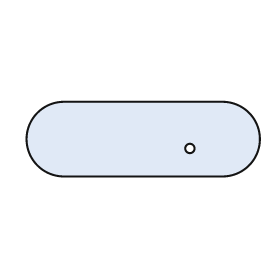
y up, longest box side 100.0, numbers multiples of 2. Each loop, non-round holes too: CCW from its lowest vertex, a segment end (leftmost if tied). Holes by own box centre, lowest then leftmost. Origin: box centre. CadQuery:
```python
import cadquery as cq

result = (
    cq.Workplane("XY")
    .moveTo(-34.0, -16.0)
    .lineTo(34.0, -16.0)
    .threePointArc((50.0, 0.0), (34.0, 16.0))
    .lineTo(-34.0, 16.0)
    .threePointArc((-50.0, 0.0), (-34.0, -16.0))
    .close()
    .moveTo(20.0, -4.0)
    .circle(2.0)
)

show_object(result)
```